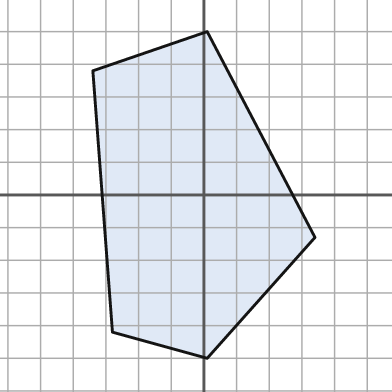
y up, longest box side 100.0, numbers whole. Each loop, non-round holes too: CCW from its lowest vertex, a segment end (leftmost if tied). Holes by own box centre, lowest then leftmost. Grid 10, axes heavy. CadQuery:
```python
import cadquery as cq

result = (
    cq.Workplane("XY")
    .moveTo(1.0, -50.0)
    .lineTo(34.0, -13.0)
    .lineTo(1.0, 50.0)
    .lineTo(-34.0, 38.0)
    .lineTo(-28.0, -42.0)
    .close()
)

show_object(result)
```